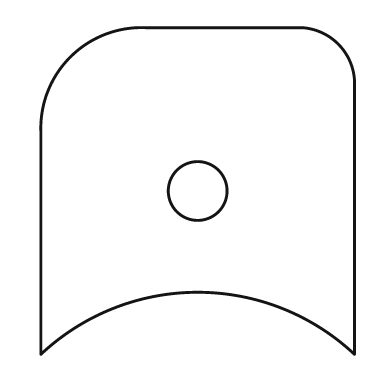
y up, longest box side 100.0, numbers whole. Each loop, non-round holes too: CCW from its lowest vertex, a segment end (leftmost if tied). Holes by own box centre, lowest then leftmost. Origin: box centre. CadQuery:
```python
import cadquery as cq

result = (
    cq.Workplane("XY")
    .moveTo(-48.0, -50.0)
    .threePointArc((0.0, -31.0), (48.0, -50.0))
    .lineTo(48.0, 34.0)
    .threePointArc((43.0, 45.0), (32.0, 50.0))
    .lineTo(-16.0, 50.0)
    .threePointArc((-39.0, 41.0), (-48.0, 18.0))
    .close()
    .moveTo(0.0, 0.0)
    .circle(9.0)
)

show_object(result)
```